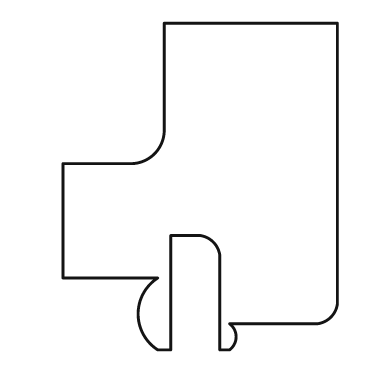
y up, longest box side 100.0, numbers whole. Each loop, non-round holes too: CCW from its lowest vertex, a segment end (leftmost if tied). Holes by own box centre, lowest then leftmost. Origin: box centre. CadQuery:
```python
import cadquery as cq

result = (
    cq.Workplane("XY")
    .moveTo(-13.0, -50.0)
    .lineTo(-9.0, -50.0)
    .lineTo(-9.0, -15.0)
    .lineTo(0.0, -15.0)
    .threePointArc((4.0, -17.0), (6.0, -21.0))
    .lineTo(6.0, -50.0)
    .lineTo(9.0, -50.0)
    .threePointArc((11.0, -46.0), (9.0, -42.0))
    .lineTo(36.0, -42.0)
    .threePointArc((40.0, -40.0), (42.0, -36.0))
    .lineTo(42.0, 50.0)
    .lineTo(-11.0, 50.0)
    .lineTo(-11.0, 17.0)
    .threePointArc((-14.0, 10.0), (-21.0, 7.0))
    .lineTo(-42.0, 7.0)
    .lineTo(-42.0, -28.0)
    .lineTo(-13.0, -28.0)
    .threePointArc((-19.0, -39.0), (-13.0, -50.0))
    .close()
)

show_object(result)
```